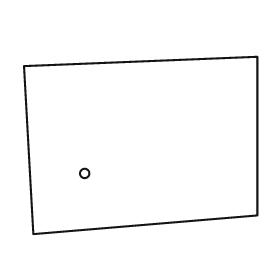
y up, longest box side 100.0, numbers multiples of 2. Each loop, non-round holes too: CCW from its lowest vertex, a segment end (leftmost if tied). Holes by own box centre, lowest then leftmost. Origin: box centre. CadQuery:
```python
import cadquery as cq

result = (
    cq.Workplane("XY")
    .moveTo(-46.0, -38.0)
    .lineTo(50.0, -30.0)
    .lineTo(50.0, 38.0)
    .lineTo(-50.0, 34.0)
    .close()
    .moveTo(-24.0, -12.0)
    .circle(2.0)
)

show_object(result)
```